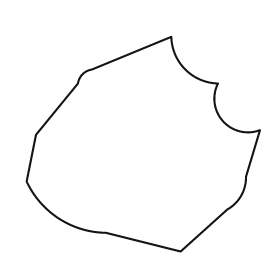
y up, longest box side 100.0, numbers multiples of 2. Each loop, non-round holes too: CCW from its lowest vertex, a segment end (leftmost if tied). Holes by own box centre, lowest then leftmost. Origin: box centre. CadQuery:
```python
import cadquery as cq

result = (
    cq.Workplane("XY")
    .moveTo(16.0, -46.0)
    .lineTo(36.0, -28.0)
    .threePointArc((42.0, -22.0), (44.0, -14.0))
    .lineTo(50.0, 6.0)
    .threePointArc((34.0, 10.0), (32.0, 26.0))
    .threePointArc((18.0, 32.0), (12.0, 46.0))
    .lineTo(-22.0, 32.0)
    .threePointArc((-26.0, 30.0), (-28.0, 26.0))
    .lineTo(-46.0, 4.0)
    .lineTo(-50.0, -16.0)
    .threePointArc((-36.0, -32.0), (-16.0, -38.0))
    .close()
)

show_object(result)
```